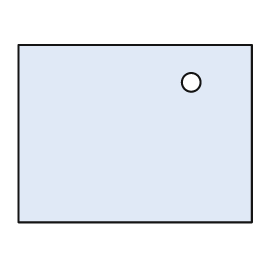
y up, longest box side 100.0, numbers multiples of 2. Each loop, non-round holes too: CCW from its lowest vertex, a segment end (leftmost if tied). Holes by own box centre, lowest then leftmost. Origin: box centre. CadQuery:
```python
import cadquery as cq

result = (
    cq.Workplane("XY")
    .moveTo(-50.0, -38.0)
    .lineTo(50.0, -38.0)
    .lineTo(50.0, 38.0)
    .lineTo(-50.0, 38.0)
    .close()
    .moveTo(24.0, 22.0)
    .circle(4.0)
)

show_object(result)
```